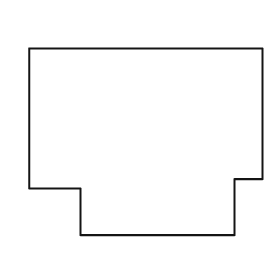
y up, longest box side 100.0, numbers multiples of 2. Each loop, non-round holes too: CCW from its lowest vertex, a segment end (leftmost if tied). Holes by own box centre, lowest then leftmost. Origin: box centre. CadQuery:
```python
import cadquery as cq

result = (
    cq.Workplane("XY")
    .moveTo(-28.0, -40.0)
    .lineTo(38.0, -40.0)
    .lineTo(38.0, -16.0)
    .lineTo(50.0, -16.0)
    .lineTo(50.0, 40.0)
    .lineTo(-50.0, 40.0)
    .lineTo(-50.0, -20.0)
    .lineTo(-28.0, -20.0)
    .close()
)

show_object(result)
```